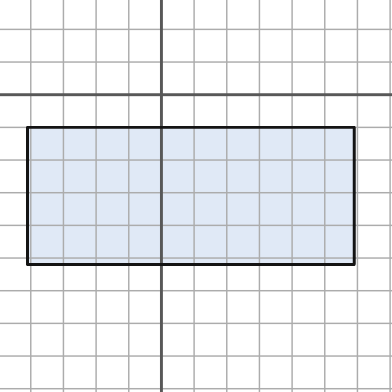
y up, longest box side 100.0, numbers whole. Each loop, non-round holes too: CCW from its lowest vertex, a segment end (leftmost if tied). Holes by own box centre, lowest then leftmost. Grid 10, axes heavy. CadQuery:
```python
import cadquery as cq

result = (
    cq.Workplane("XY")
    .moveTo(-41.0, -52.0)
    .lineTo(59.0, -52.0)
    .lineTo(59.0, -10.0)
    .lineTo(-41.0, -10.0)
    .close()
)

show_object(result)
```